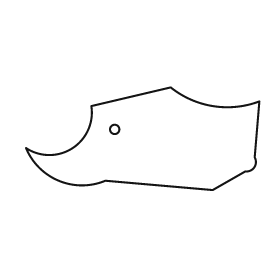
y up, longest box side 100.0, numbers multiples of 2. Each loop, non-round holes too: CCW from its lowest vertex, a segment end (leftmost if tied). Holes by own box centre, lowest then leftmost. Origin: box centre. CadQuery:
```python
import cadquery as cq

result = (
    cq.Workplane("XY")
    .moveTo(30.0, -22.0)
    .lineTo(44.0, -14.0)
    .threePointArc((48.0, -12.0), (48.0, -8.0))
    .lineTo(50.0, 16.0)
    .threePointArc((30.0, 14.0), (12.0, 22.0))
    .lineTo(-22.0, 14.0)
    .threePointArc((-30.0, -4.0), (-50.0, -4.0))
    .threePointArc((-36.0, -18.0), (-16.0, -18.0))
    .close()
    .moveTo(-12.0, 4.0)
    .circle(2.0)
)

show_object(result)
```